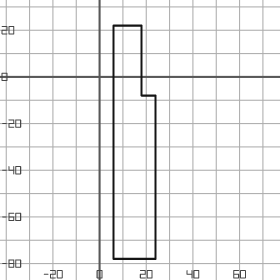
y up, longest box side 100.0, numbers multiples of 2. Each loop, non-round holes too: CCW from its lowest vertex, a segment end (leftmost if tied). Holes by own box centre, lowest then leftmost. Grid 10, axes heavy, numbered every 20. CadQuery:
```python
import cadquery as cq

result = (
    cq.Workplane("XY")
    .moveTo(6.0, -78.0)
    .lineTo(24.0, -78.0)
    .lineTo(24.0, -8.0)
    .lineTo(18.0, -8.0)
    .lineTo(18.0, 22.0)
    .lineTo(6.0, 22.0)
    .close()
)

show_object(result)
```